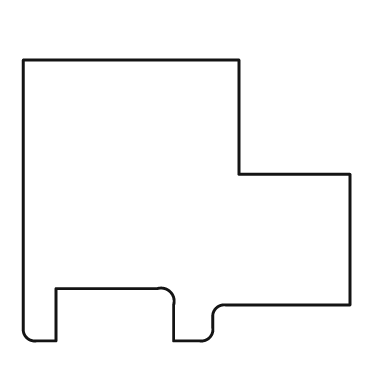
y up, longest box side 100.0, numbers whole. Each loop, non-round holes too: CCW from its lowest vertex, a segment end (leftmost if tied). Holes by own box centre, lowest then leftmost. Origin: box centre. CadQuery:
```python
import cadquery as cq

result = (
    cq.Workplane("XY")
    .moveTo(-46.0, -43.0)
    .lineTo(-40.0, -43.0)
    .lineTo(-40.0, -27.0)
    .lineTo(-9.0, -27.0)
    .threePointArc((-5.0, -28.0), (-4.0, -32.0))
    .lineTo(-4.0, -43.0)
    .lineTo(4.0, -43.0)
    .threePointArc((7.0, -42.0), (8.0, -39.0))
    .lineTo(8.0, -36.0)
    .threePointArc((9.0, -33.0), (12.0, -32.0))
    .lineTo(50.0, -32.0)
    .lineTo(50.0, 8.0)
    .lineTo(16.0, 8.0)
    .lineTo(16.0, 43.0)
    .lineTo(-50.0, 43.0)
    .lineTo(-50.0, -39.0)
    .threePointArc((-49.0, -42.0), (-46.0, -43.0))
    .close()
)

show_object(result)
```